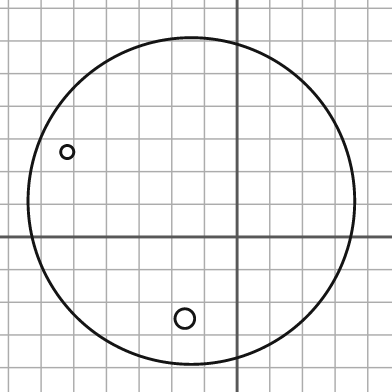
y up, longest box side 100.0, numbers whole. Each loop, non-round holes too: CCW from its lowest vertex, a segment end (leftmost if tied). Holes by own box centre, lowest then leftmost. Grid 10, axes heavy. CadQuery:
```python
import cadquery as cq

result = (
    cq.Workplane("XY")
    .moveTo(-14.0, 11.0)
    .circle(50.0)
    .moveTo(-16.0, -25.0)
    .circle(3.0)
    .moveTo(-52.0, 26.0)
    .circle(2.0)
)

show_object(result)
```